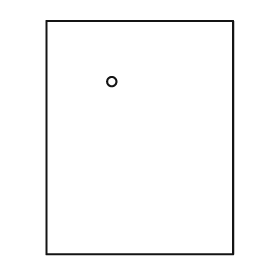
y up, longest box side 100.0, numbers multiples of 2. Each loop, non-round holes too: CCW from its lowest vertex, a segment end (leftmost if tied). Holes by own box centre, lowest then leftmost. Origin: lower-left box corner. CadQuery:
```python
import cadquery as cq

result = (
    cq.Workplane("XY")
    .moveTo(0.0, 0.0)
    .lineTo(80.0, 0.0)
    .lineTo(80.0, 100.0)
    .lineTo(0.0, 100.0)
    .close()
    .moveTo(28.0, 74.0)
    .circle(2.0)
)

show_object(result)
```